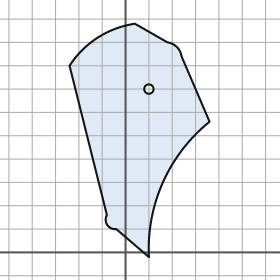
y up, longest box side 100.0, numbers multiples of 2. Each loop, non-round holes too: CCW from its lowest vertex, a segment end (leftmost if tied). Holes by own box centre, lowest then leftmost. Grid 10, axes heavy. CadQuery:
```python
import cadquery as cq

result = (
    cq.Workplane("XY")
    .moveTo(10.0, -2.0)
    .threePointArc((16.0, 30.0), (36.0, 56.0))
    .lineTo(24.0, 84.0)
    .threePointArc((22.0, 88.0), (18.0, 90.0))
    .lineTo(4.0, 98.0)
    .threePointArc((-12.0, 92.0), (-24.0, 80.0))
    .lineTo(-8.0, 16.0)
    .threePointArc((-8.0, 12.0), (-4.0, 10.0))
    .close()
    .moveTo(10.0, 70.0)
    .circle(2.0)
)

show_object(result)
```